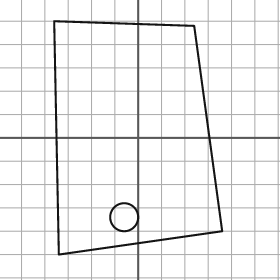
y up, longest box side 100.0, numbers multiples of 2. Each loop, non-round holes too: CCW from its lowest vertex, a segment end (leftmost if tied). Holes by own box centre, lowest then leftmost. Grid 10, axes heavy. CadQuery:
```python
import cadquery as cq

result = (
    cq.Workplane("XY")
    .moveTo(-34.0, -50.0)
    .lineTo(36.0, -40.0)
    .lineTo(24.0, 48.0)
    .lineTo(-36.0, 50.0)
    .close()
    .moveTo(-6.0, -34.0)
    .circle(6.0)
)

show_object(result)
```